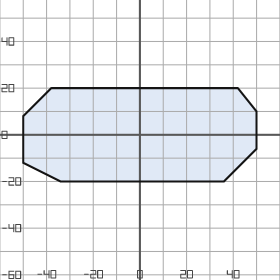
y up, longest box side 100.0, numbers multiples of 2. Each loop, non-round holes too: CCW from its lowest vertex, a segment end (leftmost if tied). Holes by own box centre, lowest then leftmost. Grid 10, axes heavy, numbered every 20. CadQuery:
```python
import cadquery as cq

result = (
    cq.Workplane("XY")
    .moveTo(-34.0, -20.0)
    .lineTo(36.0, -20.0)
    .lineTo(50.0, -6.0)
    .lineTo(50.0, 10.0)
    .lineTo(42.0, 20.0)
    .lineTo(-38.0, 20.0)
    .lineTo(-50.0, 8.0)
    .lineTo(-50.0, -12.0)
    .close()
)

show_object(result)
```